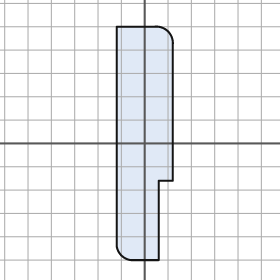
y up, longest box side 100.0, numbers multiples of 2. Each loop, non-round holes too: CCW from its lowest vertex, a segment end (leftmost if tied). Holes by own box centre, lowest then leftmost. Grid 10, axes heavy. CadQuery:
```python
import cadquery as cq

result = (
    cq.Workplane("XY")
    .moveTo(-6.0, -50.0)
    .lineTo(6.0, -50.0)
    .lineTo(6.0, -16.0)
    .lineTo(12.0, -16.0)
    .lineTo(12.0, 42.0)
    .threePointArc((10.0, 48.0), (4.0, 50.0))
    .lineTo(-12.0, 50.0)
    .lineTo(-12.0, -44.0)
    .threePointArc((-10.0, -48.0), (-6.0, -50.0))
    .close()
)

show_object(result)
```